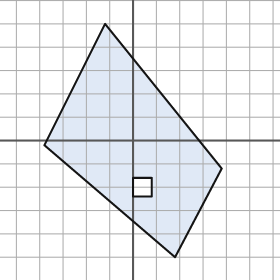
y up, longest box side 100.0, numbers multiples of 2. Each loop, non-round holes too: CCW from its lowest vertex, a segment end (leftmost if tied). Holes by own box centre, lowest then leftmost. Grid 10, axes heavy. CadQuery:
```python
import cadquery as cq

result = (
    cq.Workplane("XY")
    .moveTo(18.0, -50.0)
    .lineTo(38.0, -12.0)
    .lineTo(-12.0, 50.0)
    .lineTo(-38.0, -2.0)
    .close()
    .moveTo(0.0, -24.0)
    .lineTo(8.0, -24.0)
    .lineTo(8.0, -16.0)
    .lineTo(0.0, -16.0)
    .close()
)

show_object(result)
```